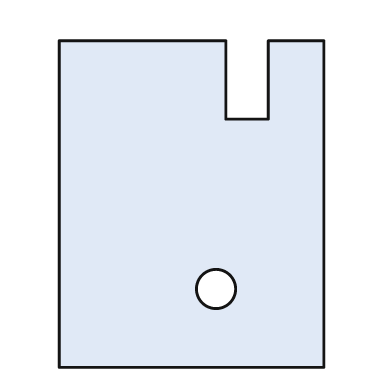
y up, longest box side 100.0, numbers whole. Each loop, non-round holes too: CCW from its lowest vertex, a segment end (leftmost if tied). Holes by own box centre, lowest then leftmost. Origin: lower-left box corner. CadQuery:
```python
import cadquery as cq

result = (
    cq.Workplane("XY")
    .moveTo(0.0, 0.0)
    .lineTo(81.0, 0.0)
    .lineTo(81.0, 100.0)
    .lineTo(64.0, 100.0)
    .lineTo(64.0, 76.0)
    .lineTo(51.0, 76.0)
    .lineTo(51.0, 100.0)
    .lineTo(0.0, 100.0)
    .close()
    .moveTo(48.0, 24.0)
    .circle(6.0)
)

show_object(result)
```